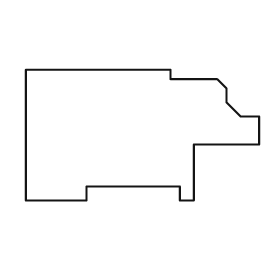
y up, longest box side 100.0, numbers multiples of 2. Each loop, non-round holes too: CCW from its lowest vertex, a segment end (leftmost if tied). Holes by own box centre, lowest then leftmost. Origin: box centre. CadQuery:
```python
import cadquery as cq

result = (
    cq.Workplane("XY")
    .moveTo(-50.0, -28.0)
    .lineTo(-24.0, -28.0)
    .lineTo(-24.0, -22.0)
    .lineTo(16.0, -22.0)
    .lineTo(16.0, -28.0)
    .lineTo(22.0, -28.0)
    .lineTo(22.0, -4.0)
    .lineTo(50.0, -4.0)
    .lineTo(50.0, 8.0)
    .lineTo(42.0, 8.0)
    .lineTo(36.0, 14.0)
    .lineTo(36.0, 20.0)
    .lineTo(32.0, 24.0)
    .lineTo(12.0, 24.0)
    .lineTo(12.0, 28.0)
    .lineTo(-50.0, 28.0)
    .close()
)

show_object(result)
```